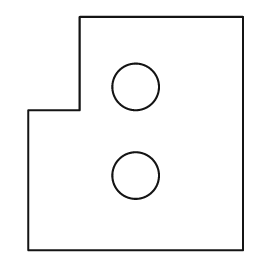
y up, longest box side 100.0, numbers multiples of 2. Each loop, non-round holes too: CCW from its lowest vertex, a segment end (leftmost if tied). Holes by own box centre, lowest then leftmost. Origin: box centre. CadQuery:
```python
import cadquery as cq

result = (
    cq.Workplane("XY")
    .moveTo(-46.0, -50.0)
    .lineTo(46.0, -50.0)
    .lineTo(46.0, 50.0)
    .lineTo(-24.0, 50.0)
    .lineTo(-24.0, 10.0)
    .lineTo(-46.0, 10.0)
    .close()
    .moveTo(0.0, -18.0)
    .circle(10.0)
    .moveTo(0.0, 20.0)
    .circle(10.0)
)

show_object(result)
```